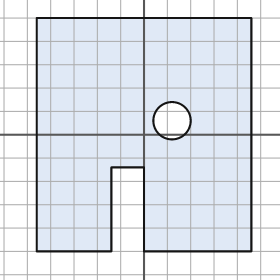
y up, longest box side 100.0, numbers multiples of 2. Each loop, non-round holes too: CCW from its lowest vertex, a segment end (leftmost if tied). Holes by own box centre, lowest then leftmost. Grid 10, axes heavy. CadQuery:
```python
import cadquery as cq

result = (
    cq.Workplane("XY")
    .moveTo(-46.0, -50.0)
    .lineTo(-14.0, -50.0)
    .lineTo(-14.0, -14.0)
    .lineTo(0.0, -14.0)
    .lineTo(0.0, -50.0)
    .lineTo(46.0, -50.0)
    .lineTo(46.0, 50.0)
    .lineTo(-46.0, 50.0)
    .close()
    .moveTo(12.0, 6.0)
    .circle(8.0)
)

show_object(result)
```